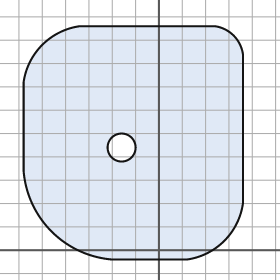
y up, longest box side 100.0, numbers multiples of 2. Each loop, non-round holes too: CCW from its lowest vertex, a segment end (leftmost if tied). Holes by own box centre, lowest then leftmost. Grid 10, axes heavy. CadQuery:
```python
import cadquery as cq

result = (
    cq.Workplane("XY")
    .moveTo(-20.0, -4.0)
    .lineTo(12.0, -4.0)
    .threePointArc((28.0, 4.0), (36.0, 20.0))
    .lineTo(36.0, 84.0)
    .threePointArc((32.0, 92.0), (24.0, 96.0))
    .lineTo(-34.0, 96.0)
    .threePointArc((-50.0, 88.0), (-58.0, 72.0))
    .lineTo(-58.0, 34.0)
    .threePointArc((-46.0, 8.0), (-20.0, -4.0))
    .close()
    .moveTo(-16.0, 44.0)
    .circle(6.0)
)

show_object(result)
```